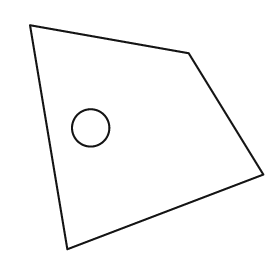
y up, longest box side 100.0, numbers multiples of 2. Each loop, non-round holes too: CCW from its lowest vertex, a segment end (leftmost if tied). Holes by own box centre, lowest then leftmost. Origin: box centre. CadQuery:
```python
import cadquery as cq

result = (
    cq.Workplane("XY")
    .moveTo(-34.0, -48.0)
    .lineTo(50.0, -16.0)
    .lineTo(18.0, 36.0)
    .lineTo(-50.0, 48.0)
    .close()
    .moveTo(-24.0, 4.0)
    .circle(8.0)
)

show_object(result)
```